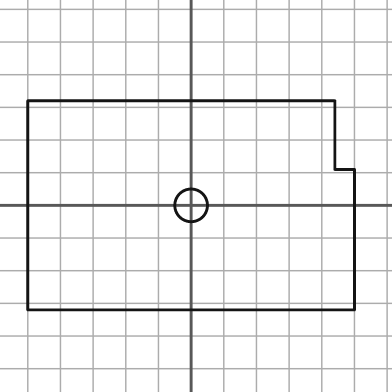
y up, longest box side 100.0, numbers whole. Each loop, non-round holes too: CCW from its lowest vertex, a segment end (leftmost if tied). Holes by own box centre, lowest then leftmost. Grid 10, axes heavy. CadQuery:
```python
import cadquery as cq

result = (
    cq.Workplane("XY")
    .moveTo(-50.0, -32.0)
    .lineTo(50.0, -32.0)
    .lineTo(50.0, 11.0)
    .lineTo(44.0, 11.0)
    .lineTo(44.0, 32.0)
    .lineTo(-50.0, 32.0)
    .close()
    .moveTo(0.0, 0.0)
    .circle(5.0)
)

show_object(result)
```